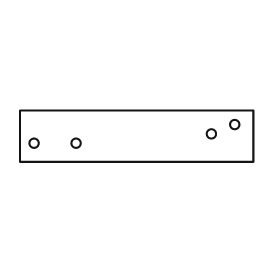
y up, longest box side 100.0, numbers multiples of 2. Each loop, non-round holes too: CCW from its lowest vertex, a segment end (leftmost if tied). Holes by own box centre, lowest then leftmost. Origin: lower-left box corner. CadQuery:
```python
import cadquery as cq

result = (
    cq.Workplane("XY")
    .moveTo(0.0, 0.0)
    .lineTo(100.0, 0.0)
    .lineTo(100.0, 22.0)
    .lineTo(0.0, 22.0)
    .close()
    .moveTo(6.0, 8.0)
    .circle(2.0)
    .moveTo(24.0, 8.0)
    .circle(2.0)
    .moveTo(82.0, 12.0)
    .circle(2.0)
    .moveTo(92.0, 16.0)
    .circle(2.0)
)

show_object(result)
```